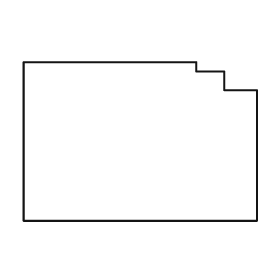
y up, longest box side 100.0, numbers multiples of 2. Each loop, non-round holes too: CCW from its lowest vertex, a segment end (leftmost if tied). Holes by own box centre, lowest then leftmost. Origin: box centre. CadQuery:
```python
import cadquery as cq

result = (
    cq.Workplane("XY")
    .moveTo(-50.0, -34.0)
    .lineTo(50.0, -34.0)
    .lineTo(50.0, 22.0)
    .lineTo(36.0, 22.0)
    .lineTo(36.0, 30.0)
    .lineTo(24.0, 30.0)
    .lineTo(24.0, 34.0)
    .lineTo(-50.0, 34.0)
    .close()
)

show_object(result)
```